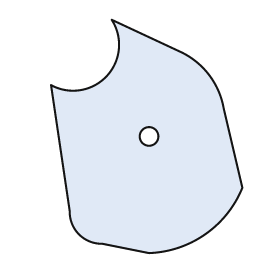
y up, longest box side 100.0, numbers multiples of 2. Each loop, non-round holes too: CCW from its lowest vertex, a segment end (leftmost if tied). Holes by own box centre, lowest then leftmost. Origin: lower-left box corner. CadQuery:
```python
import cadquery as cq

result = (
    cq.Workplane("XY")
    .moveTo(42.0, 0.0)
    .threePointArc((66.0, 8.0), (82.0, 28.0))
    .lineTo(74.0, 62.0)
    .threePointArc((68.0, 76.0), (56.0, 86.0))
    .lineTo(26.0, 100.0)
    .threePointArc((24.0, 76.0), (0.0, 72.0))
    .lineTo(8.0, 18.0)
    .threePointArc((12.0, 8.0), (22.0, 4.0))
    .close()
    .moveTo(42.0, 50.0)
    .circle(4.0)
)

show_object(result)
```